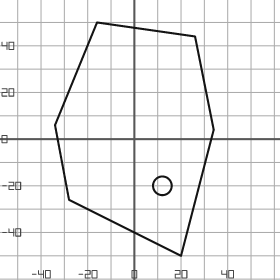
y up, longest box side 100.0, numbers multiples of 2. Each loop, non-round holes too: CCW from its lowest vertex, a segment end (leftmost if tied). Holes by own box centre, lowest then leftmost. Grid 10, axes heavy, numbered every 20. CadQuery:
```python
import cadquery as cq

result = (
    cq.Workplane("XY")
    .moveTo(20.0, -50.0)
    .lineTo(34.0, 4.0)
    .lineTo(26.0, 44.0)
    .lineTo(-16.0, 50.0)
    .lineTo(-34.0, 6.0)
    .lineTo(-28.0, -26.0)
    .close()
    .moveTo(12.0, -20.0)
    .circle(4.0)
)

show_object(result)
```